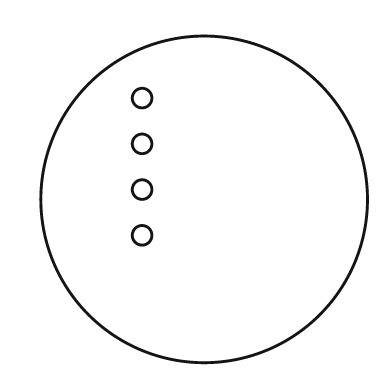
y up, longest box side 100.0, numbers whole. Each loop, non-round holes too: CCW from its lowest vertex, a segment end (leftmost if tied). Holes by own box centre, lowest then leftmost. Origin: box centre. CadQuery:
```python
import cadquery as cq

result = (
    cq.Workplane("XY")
    .moveTo(0.0, 0.0)
    .circle(50.0)
    .moveTo(-19.0, -11.0)
    .circle(3.0)
    .moveTo(-19.0, 3.0)
    .circle(3.0)
    .moveTo(-19.0, 17.0)
    .circle(3.0)
    .moveTo(-19.0, 31.0)
    .circle(3.0)
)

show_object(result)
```